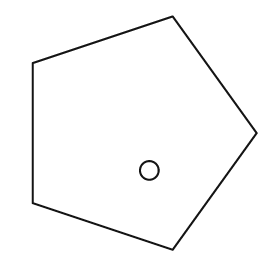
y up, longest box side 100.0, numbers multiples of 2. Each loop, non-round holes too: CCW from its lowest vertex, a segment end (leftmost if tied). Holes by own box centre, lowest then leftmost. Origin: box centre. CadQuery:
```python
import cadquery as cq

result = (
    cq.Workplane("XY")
    .moveTo(12.0, -50.0)
    .lineTo(48.0, 0.0)
    .lineTo(12.0, 50.0)
    .lineTo(-48.0, 30.0)
    .lineTo(-48.0, -30.0)
    .close()
    .moveTo(2.0, -16.0)
    .circle(4.0)
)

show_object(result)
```